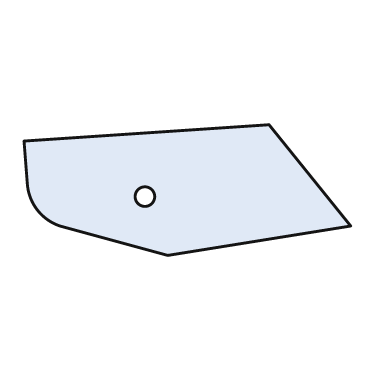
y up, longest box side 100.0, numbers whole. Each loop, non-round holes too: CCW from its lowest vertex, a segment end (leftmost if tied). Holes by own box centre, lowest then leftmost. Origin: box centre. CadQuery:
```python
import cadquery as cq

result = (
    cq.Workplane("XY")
    .moveTo(-6.0, -20.0)
    .lineTo(50.0, -11.0)
    .lineTo(25.0, 20.0)
    .lineTo(-50.0, 15.0)
    .lineTo(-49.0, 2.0)
    .threePointArc((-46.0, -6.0), (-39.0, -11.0))
    .close()
    .moveTo(-13.0, -2.0)
    .circle(3.0)
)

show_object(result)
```